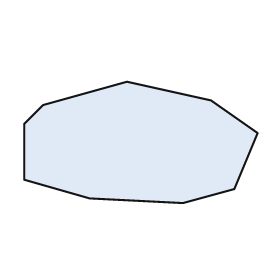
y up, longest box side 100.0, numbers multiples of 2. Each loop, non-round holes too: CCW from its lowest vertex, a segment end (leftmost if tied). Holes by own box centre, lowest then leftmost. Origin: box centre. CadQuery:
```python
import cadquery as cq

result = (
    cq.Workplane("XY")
    .moveTo(18.0, -26.0)
    .lineTo(40.0, -20.0)
    .lineTo(50.0, 4.0)
    .lineTo(30.0, 18.0)
    .lineTo(-6.0, 26.0)
    .lineTo(-42.0, 16.0)
    .lineTo(-50.0, 8.0)
    .lineTo(-50.0, -16.0)
    .lineTo(-22.0, -24.0)
    .close()
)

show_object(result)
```